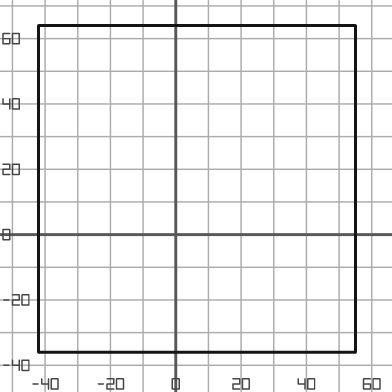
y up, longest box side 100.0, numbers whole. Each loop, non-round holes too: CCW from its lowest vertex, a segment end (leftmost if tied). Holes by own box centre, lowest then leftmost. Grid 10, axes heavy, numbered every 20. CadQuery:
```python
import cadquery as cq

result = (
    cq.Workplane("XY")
    .moveTo(-42.0, -36.0)
    .lineTo(55.0, -36.0)
    .lineTo(55.0, 64.0)
    .lineTo(-42.0, 64.0)
    .close()
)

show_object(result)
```